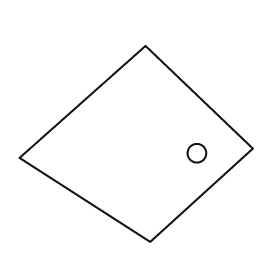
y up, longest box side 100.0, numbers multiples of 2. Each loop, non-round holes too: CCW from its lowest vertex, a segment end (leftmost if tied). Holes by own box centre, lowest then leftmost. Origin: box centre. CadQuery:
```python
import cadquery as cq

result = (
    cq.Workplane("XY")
    .moveTo(6.0, -42.0)
    .lineTo(50.0, -2.0)
    .lineTo(4.0, 42.0)
    .lineTo(-50.0, -6.0)
    .close()
    .moveTo(26.0, -4.0)
    .circle(4.0)
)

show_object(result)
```